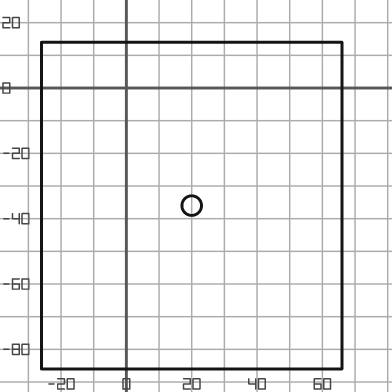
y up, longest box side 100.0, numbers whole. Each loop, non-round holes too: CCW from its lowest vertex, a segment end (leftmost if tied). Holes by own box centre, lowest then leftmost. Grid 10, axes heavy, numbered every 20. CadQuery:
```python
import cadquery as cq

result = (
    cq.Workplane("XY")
    .moveTo(-26.0, -86.0)
    .lineTo(66.0, -86.0)
    .lineTo(66.0, 14.0)
    .lineTo(-26.0, 14.0)
    .close()
    .moveTo(20.0, -36.0)
    .circle(3.0)
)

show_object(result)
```